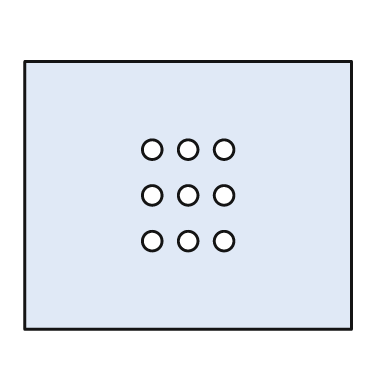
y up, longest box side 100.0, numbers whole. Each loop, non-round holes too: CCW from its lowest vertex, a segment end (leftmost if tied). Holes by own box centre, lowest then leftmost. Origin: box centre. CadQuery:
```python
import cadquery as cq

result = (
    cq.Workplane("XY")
    .moveTo(-50.0, -41.0)
    .lineTo(50.0, -41.0)
    .lineTo(50.0, 41.0)
    .lineTo(-50.0, 41.0)
    .close()
    .moveTo(-11.0, -14.0)
    .circle(3.0)
    .moveTo(0.0, -14.0)
    .circle(3.0)
    .moveTo(11.0, -14.0)
    .circle(3.0)
    .moveTo(-11.0, 0.0)
    .circle(3.0)
    .moveTo(0.0, 0.0)
    .circle(3.0)
    .moveTo(11.0, 0.0)
    .circle(3.0)
    .moveTo(-11.0, 14.0)
    .circle(3.0)
    .moveTo(0.0, 14.0)
    .circle(3.0)
    .moveTo(11.0, 14.0)
    .circle(3.0)
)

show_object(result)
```